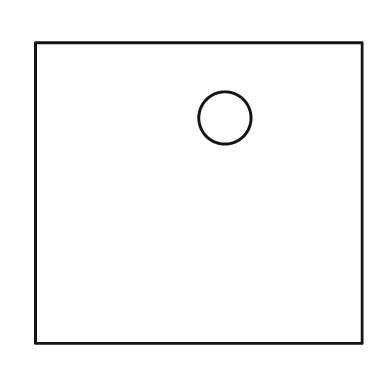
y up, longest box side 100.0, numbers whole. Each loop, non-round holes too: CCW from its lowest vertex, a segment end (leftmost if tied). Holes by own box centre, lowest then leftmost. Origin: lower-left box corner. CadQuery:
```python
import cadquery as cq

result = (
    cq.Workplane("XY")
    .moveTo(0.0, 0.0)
    .lineTo(100.0, 0.0)
    .lineTo(100.0, 92.0)
    .lineTo(0.0, 92.0)
    .close()
    .moveTo(58.0, 69.0)
    .circle(8.0)
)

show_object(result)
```